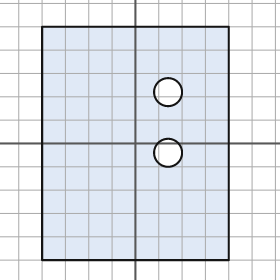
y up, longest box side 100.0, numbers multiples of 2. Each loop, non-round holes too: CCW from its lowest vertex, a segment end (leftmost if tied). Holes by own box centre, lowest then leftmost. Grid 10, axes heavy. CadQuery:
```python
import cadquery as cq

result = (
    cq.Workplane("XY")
    .moveTo(-40.0, -50.0)
    .lineTo(40.0, -50.0)
    .lineTo(40.0, 50.0)
    .lineTo(-40.0, 50.0)
    .close()
    .moveTo(14.0, -4.0)
    .circle(6.0)
    .moveTo(14.0, 22.0)
    .circle(6.0)
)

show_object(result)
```